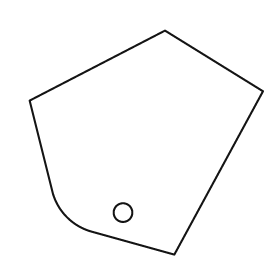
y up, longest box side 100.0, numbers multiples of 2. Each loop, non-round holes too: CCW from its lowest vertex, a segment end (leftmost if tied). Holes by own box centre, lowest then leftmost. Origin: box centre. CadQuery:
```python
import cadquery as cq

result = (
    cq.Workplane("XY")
    .moveTo(12.0, -48.0)
    .lineTo(50.0, 22.0)
    .lineTo(8.0, 48.0)
    .lineTo(-50.0, 18.0)
    .lineTo(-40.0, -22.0)
    .threePointArc((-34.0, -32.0), (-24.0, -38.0))
    .close()
    .moveTo(-10.0, -30.0)
    .circle(4.0)
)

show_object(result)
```